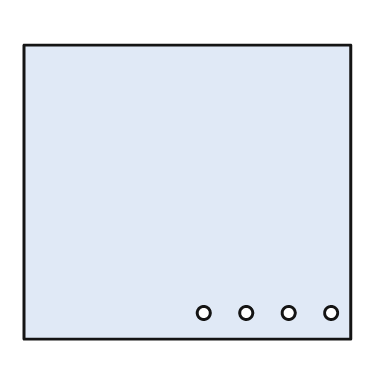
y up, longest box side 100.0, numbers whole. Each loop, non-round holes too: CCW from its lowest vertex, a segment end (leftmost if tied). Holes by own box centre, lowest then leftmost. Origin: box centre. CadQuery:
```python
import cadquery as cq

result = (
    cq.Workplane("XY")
    .moveTo(-50.0, -45.0)
    .lineTo(50.0, -45.0)
    .lineTo(50.0, 45.0)
    .lineTo(-50.0, 45.0)
    .close()
    .moveTo(5.0, -37.0)
    .circle(2.0)
    .moveTo(18.0, -37.0)
    .circle(2.0)
    .moveTo(31.0, -37.0)
    .circle(2.0)
    .moveTo(44.0, -37.0)
    .circle(2.0)
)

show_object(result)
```